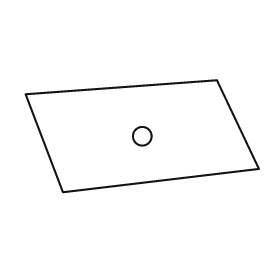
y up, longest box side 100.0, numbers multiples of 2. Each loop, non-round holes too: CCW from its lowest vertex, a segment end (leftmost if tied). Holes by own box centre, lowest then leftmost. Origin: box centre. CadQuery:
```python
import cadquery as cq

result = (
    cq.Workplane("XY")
    .moveTo(-34.0, -24.0)
    .lineTo(50.0, -14.0)
    .lineTo(32.0, 24.0)
    .lineTo(-50.0, 18.0)
    .close()
    .moveTo(0.0, 0.0)
    .circle(4.0)
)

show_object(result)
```